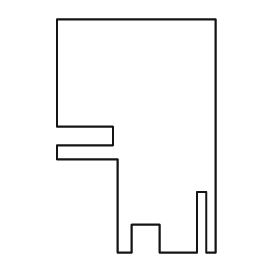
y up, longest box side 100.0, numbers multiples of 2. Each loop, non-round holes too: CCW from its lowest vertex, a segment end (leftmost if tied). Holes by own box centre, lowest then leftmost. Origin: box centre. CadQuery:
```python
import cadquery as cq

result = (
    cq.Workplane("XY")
    .moveTo(-8.0, -50.0)
    .lineTo(-2.0, -50.0)
    .lineTo(-2.0, -38.0)
    .lineTo(10.0, -38.0)
    .lineTo(10.0, -50.0)
    .lineTo(26.0, -50.0)
    .lineTo(26.0, -24.0)
    .lineTo(30.0, -24.0)
    .lineTo(30.0, -50.0)
    .lineTo(34.0, -50.0)
    .lineTo(34.0, 50.0)
    .lineTo(-34.0, 50.0)
    .lineTo(-34.0, 4.0)
    .lineTo(-10.0, 4.0)
    .lineTo(-10.0, -4.0)
    .lineTo(-34.0, -4.0)
    .lineTo(-34.0, -10.0)
    .lineTo(-8.0, -10.0)
    .close()
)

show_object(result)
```